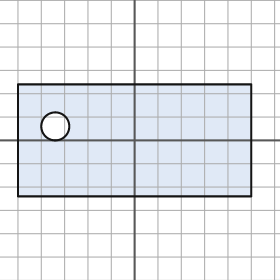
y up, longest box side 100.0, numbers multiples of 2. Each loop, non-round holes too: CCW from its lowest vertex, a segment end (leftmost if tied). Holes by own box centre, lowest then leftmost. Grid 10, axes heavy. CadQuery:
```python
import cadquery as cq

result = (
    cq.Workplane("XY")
    .moveTo(-50.0, -24.0)
    .lineTo(50.0, -24.0)
    .lineTo(50.0, 24.0)
    .lineTo(-50.0, 24.0)
    .close()
    .moveTo(-34.0, 6.0)
    .circle(6.0)
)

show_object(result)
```